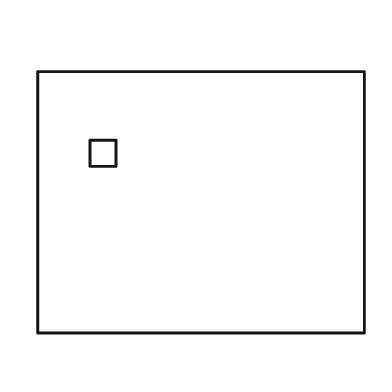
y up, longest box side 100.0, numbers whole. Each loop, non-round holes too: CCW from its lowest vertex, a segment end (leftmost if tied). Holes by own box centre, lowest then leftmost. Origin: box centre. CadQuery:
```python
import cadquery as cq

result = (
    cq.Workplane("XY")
    .moveTo(-50.0, -40.0)
    .lineTo(50.0, -40.0)
    .lineTo(50.0, 40.0)
    .lineTo(-50.0, 40.0)
    .close()
    .moveTo(-34.0, 11.0)
    .lineTo(-26.0, 11.0)
    .lineTo(-26.0, 19.0)
    .lineTo(-34.0, 19.0)
    .close()
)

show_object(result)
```